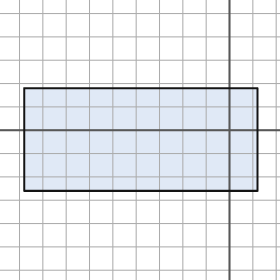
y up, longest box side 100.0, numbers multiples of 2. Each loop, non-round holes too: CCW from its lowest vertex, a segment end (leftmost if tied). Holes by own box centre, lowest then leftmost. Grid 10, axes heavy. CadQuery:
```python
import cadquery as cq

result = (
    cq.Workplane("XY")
    .moveTo(-88.0, -26.0)
    .lineTo(12.0, -26.0)
    .lineTo(12.0, 18.0)
    .lineTo(-88.0, 18.0)
    .close()
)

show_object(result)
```